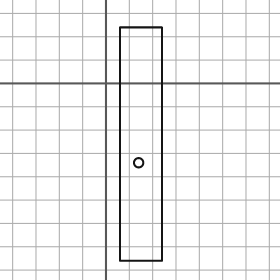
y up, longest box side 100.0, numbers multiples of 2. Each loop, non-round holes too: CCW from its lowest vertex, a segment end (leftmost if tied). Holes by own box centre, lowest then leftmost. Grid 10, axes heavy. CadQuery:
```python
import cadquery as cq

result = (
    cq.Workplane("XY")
    .moveTo(6.0, -76.0)
    .lineTo(24.0, -76.0)
    .lineTo(24.0, 24.0)
    .lineTo(6.0, 24.0)
    .close()
    .moveTo(14.0, -34.0)
    .circle(2.0)
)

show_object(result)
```